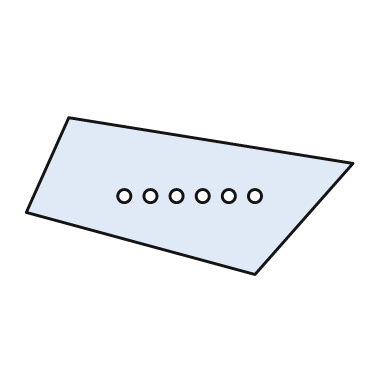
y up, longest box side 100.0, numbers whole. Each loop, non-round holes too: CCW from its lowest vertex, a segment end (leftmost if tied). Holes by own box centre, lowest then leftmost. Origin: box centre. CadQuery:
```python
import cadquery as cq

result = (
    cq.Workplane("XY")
    .moveTo(20.0, -24.0)
    .lineTo(50.0, 10.0)
    .lineTo(-37.0, 24.0)
    .lineTo(-50.0, -5.0)
    .close()
    .moveTo(-20.0, 0.0)
    .circle(2.0)
    .moveTo(-12.0, 0.0)
    .circle(2.0)
    .moveTo(-4.0, 0.0)
    .circle(2.0)
    .moveTo(4.0, 0.0)
    .circle(2.0)
    .moveTo(12.0, 0.0)
    .circle(2.0)
    .moveTo(20.0, 0.0)
    .circle(2.0)
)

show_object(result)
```